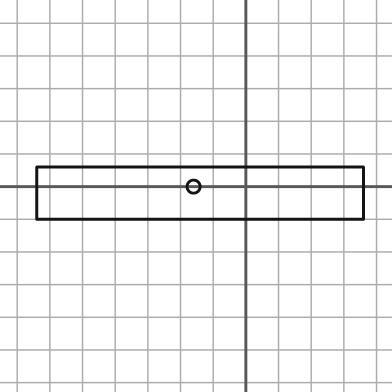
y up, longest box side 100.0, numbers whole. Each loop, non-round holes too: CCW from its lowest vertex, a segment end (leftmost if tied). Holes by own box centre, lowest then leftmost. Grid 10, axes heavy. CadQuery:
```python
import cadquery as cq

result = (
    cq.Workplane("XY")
    .moveTo(-64.0, -10.0)
    .lineTo(36.0, -10.0)
    .lineTo(36.0, 6.0)
    .lineTo(-64.0, 6.0)
    .close()
    .moveTo(-16.0, 0.0)
    .circle(2.0)
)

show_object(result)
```